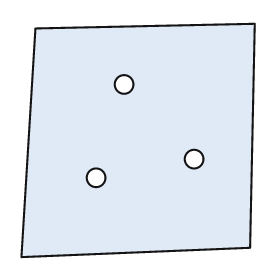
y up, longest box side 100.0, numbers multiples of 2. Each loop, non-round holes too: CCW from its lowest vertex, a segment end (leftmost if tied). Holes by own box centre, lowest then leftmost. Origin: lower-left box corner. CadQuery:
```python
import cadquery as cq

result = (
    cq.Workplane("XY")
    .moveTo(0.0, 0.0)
    .lineTo(98.0, 4.0)
    .lineTo(100.0, 100.0)
    .lineTo(6.0, 98.0)
    .close()
    .moveTo(32.0, 34.0)
    .circle(4.0)
    .moveTo(74.0, 42.0)
    .circle(4.0)
    .moveTo(44.0, 74.0)
    .circle(4.0)
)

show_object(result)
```